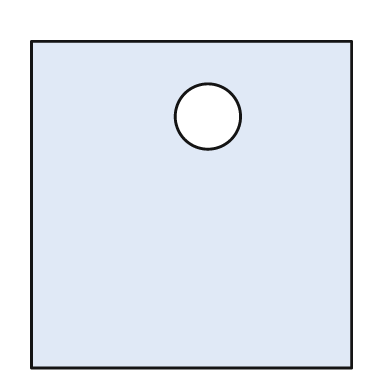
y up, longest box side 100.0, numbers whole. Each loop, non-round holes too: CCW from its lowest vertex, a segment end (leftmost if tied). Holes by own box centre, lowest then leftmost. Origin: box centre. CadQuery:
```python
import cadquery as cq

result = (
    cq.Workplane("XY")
    .moveTo(-49.0, -50.0)
    .lineTo(49.0, -50.0)
    .lineTo(49.0, 50.0)
    .lineTo(-49.0, 50.0)
    .close()
    .moveTo(5.0, 27.0)
    .circle(10.0)
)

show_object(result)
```